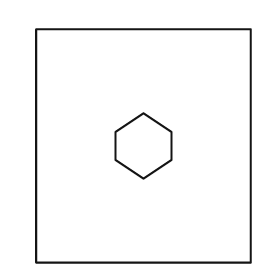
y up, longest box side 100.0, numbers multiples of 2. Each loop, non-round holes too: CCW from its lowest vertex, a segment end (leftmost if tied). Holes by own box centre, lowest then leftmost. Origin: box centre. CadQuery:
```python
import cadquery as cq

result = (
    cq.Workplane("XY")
    .moveTo(-46.0, -50.0)
    .lineTo(46.0, -50.0)
    .lineTo(46.0, 50.0)
    .lineTo(-46.0, 50.0)
    .close()
    .moveTo(0.0, -14.0)
    .lineTo(12.0, -6.0)
    .lineTo(12.0, 6.0)
    .lineTo(0.0, 14.0)
    .lineTo(-12.0, 6.0)
    .lineTo(-12.0, -6.0)
    .close()
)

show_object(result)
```